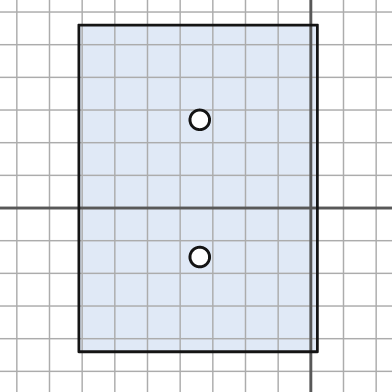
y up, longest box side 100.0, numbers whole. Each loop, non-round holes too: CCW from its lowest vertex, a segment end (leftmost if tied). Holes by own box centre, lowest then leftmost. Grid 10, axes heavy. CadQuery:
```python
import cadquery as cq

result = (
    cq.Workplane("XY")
    .moveTo(-71.0, -44.0)
    .lineTo(2.0, -44.0)
    .lineTo(2.0, 56.0)
    .lineTo(-71.0, 56.0)
    .close()
    .moveTo(-34.0, -15.0)
    .circle(3.0)
    .moveTo(-34.0, 27.0)
    .circle(3.0)
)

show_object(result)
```